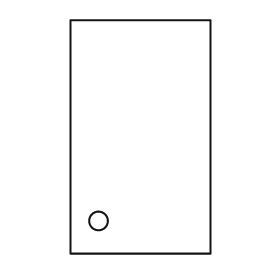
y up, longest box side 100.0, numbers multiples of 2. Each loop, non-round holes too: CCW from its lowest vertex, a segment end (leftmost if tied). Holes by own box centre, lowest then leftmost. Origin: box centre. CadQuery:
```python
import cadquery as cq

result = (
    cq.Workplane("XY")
    .moveTo(-30.0, -50.0)
    .lineTo(30.0, -50.0)
    .lineTo(30.0, 50.0)
    .lineTo(-30.0, 50.0)
    .close()
    .moveTo(-18.0, -36.0)
    .circle(4.0)
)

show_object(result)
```